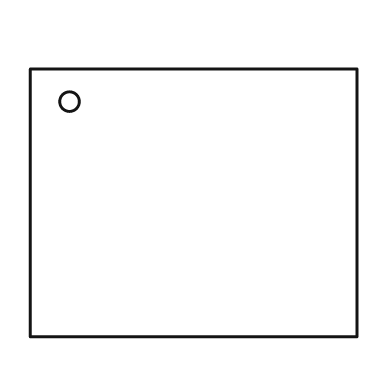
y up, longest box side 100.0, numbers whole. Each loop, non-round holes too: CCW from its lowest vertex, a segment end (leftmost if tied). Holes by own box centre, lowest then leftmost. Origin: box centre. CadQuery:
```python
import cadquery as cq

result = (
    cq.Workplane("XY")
    .moveTo(-50.0, -41.0)
    .lineTo(50.0, -41.0)
    .lineTo(50.0, 41.0)
    .lineTo(-50.0, 41.0)
    .close()
    .moveTo(-38.0, 31.0)
    .circle(3.0)
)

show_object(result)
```